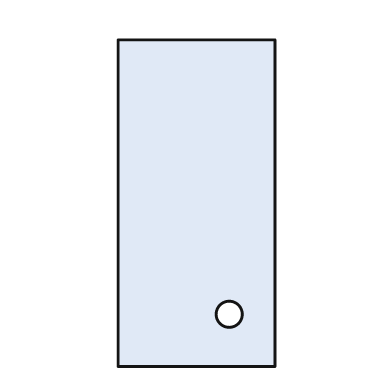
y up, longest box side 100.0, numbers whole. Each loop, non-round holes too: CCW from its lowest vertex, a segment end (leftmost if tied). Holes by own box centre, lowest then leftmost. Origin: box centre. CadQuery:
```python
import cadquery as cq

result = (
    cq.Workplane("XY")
    .moveTo(-24.0, -50.0)
    .lineTo(24.0, -50.0)
    .lineTo(24.0, 50.0)
    .lineTo(-24.0, 50.0)
    .close()
    .moveTo(10.0, -34.0)
    .circle(4.0)
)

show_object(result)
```